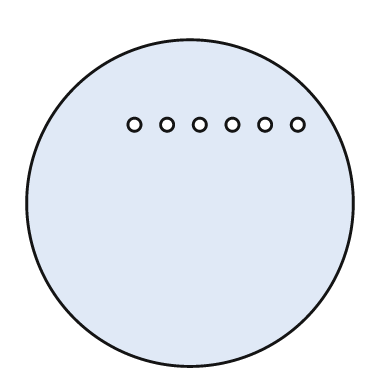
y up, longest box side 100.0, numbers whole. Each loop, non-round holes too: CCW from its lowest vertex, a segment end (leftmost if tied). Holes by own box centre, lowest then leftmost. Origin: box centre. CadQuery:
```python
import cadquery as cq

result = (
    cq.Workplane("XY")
    .moveTo(0.0, 0.0)
    .circle(50.0)
    .moveTo(-17.0, 24.0)
    .circle(2.0)
    .moveTo(-7.0, 24.0)
    .circle(2.0)
    .moveTo(3.0, 24.0)
    .circle(2.0)
    .moveTo(13.0, 24.0)
    .circle(2.0)
    .moveTo(23.0, 24.0)
    .circle(2.0)
    .moveTo(33.0, 24.0)
    .circle(2.0)
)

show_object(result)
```